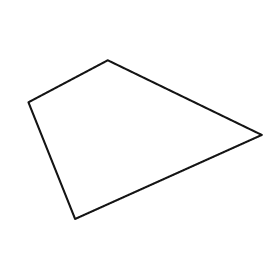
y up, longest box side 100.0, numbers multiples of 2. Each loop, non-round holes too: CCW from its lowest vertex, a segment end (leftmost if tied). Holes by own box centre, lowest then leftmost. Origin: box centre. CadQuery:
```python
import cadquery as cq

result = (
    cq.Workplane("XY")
    .moveTo(-30.0, -34.0)
    .lineTo(50.0, 2.0)
    .lineTo(-16.0, 34.0)
    .lineTo(-50.0, 16.0)
    .close()
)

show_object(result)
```